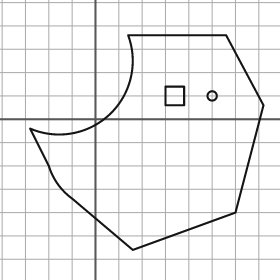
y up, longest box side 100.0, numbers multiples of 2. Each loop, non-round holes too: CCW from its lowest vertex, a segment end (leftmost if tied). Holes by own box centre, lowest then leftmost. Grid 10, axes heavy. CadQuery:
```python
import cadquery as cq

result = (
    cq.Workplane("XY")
    .moveTo(16.0, -56.0)
    .lineTo(60.0, -40.0)
    .lineTo(72.0, 6.0)
    .lineTo(56.0, 36.0)
    .lineTo(14.0, 36.0)
    .threePointArc((6.0, 2.0), (-28.0, -4.0))
    .lineTo(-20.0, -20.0)
    .threePointArc((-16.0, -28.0), (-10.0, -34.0))
    .close()
    .moveTo(30.0, 6.0)
    .lineTo(38.0, 6.0)
    .lineTo(38.0, 14.0)
    .lineTo(30.0, 14.0)
    .close()
    .moveTo(50.0, 10.0)
    .circle(2.0)
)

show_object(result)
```